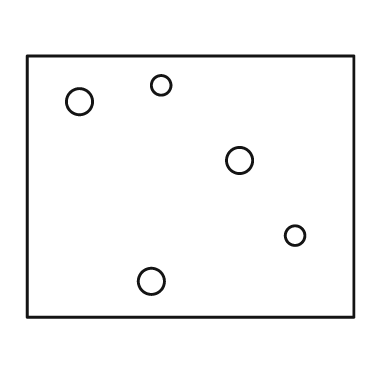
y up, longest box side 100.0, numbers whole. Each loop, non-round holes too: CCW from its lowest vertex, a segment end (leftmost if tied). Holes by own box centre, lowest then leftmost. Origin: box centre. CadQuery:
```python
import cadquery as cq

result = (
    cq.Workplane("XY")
    .moveTo(-50.0, -40.0)
    .lineTo(50.0, -40.0)
    .lineTo(50.0, 40.0)
    .lineTo(-50.0, 40.0)
    .close()
    .moveTo(-12.0, -29.0)
    .circle(4.0)
    .moveTo(32.0, -15.0)
    .circle(3.0)
    .moveTo(15.0, 8.0)
    .circle(4.0)
    .moveTo(-34.0, 26.0)
    .circle(4.0)
    .moveTo(-9.0, 31.0)
    .circle(3.0)
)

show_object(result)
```